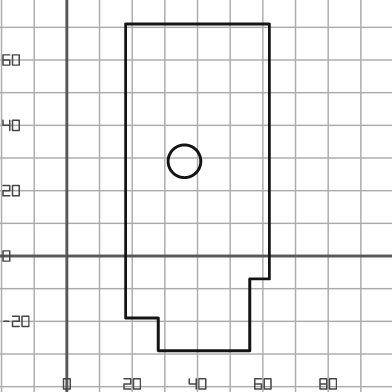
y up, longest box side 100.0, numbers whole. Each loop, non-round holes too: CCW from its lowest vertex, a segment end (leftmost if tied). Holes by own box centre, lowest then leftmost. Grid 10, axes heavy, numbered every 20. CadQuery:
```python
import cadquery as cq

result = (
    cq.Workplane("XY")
    .moveTo(28.0, -29.0)
    .lineTo(56.0, -29.0)
    .lineTo(56.0, -7.0)
    .lineTo(62.0, -7.0)
    .lineTo(62.0, 71.0)
    .lineTo(18.0, 71.0)
    .lineTo(18.0, -19.0)
    .lineTo(28.0, -19.0)
    .close()
    .moveTo(36.0, 29.0)
    .circle(5.0)
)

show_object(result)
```